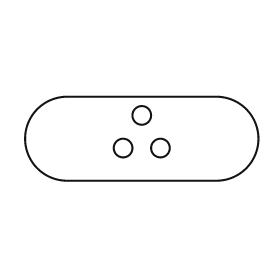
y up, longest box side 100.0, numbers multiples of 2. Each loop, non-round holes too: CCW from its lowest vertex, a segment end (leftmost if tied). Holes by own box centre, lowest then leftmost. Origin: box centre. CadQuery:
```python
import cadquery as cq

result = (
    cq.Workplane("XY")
    .moveTo(-32.0, -18.0)
    .lineTo(32.0, -18.0)
    .threePointArc((50.0, 0.0), (32.0, 18.0))
    .lineTo(-32.0, 18.0)
    .threePointArc((-50.0, 0.0), (-32.0, -18.0))
    .close()
    .moveTo(-8.0, -4.0)
    .circle(4.0)
    .moveTo(8.0, -4.0)
    .circle(4.0)
    .moveTo(0.0, 10.0)
    .circle(4.0)
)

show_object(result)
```